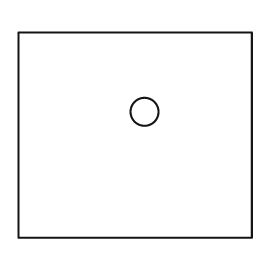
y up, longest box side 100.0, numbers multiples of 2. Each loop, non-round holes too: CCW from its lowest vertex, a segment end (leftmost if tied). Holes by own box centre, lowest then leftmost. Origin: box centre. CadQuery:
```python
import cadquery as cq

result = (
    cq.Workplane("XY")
    .moveTo(-50.0, -44.0)
    .lineTo(50.0, -44.0)
    .lineTo(50.0, 44.0)
    .lineTo(-50.0, 44.0)
    .close()
    .moveTo(4.0, 10.0)
    .circle(6.0)
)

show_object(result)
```